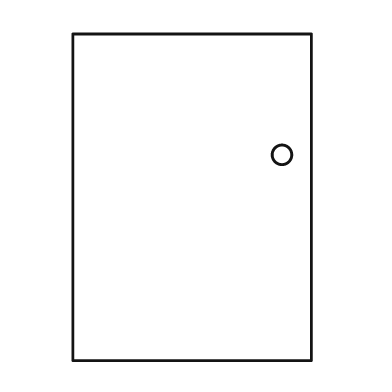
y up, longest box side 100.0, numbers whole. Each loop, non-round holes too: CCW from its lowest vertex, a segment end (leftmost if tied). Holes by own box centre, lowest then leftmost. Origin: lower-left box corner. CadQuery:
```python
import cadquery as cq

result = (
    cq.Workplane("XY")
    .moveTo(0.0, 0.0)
    .lineTo(73.0, 0.0)
    .lineTo(73.0, 100.0)
    .lineTo(0.0, 100.0)
    .close()
    .moveTo(64.0, 63.0)
    .circle(3.0)
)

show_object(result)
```